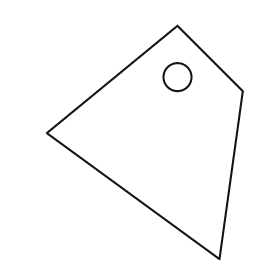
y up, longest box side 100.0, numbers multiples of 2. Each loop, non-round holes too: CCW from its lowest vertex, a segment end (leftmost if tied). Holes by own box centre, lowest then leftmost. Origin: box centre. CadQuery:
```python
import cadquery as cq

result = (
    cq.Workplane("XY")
    .moveTo(32.0, -50.0)
    .lineTo(42.0, 22.0)
    .lineTo(14.0, 50.0)
    .lineTo(-42.0, 4.0)
    .close()
    .moveTo(14.0, 28.0)
    .circle(6.0)
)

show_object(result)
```